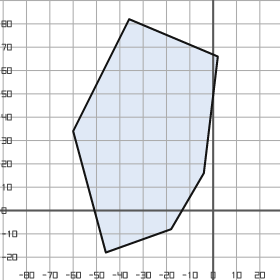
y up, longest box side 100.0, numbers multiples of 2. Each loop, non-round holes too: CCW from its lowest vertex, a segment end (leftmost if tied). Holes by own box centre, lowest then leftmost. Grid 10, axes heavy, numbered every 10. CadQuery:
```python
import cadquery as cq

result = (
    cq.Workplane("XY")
    .moveTo(-46.0, -18.0)
    .lineTo(-18.0, -8.0)
    .lineTo(-4.0, 16.0)
    .lineTo(2.0, 66.0)
    .lineTo(-36.0, 82.0)
    .lineTo(-60.0, 34.0)
    .close()
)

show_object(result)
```